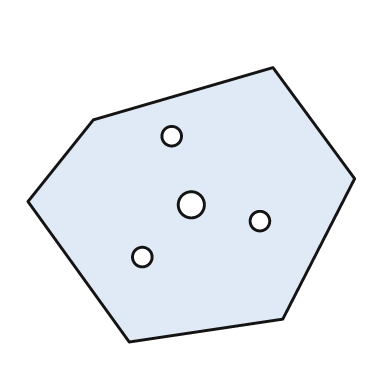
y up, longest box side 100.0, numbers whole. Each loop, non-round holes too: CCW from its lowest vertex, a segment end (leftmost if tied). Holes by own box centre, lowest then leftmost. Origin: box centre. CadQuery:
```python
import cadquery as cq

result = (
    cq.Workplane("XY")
    .moveTo(-19.0, -42.0)
    .lineTo(28.0, -35.0)
    .lineTo(50.0, 8.0)
    .lineTo(25.0, 42.0)
    .lineTo(-30.0, 26.0)
    .lineTo(-50.0, 1.0)
    .close()
    .moveTo(-15.0, -16.0)
    .circle(3.0)
    .moveTo(21.0, -5.0)
    .circle(3.0)
    .moveTo(0.0, 0.0)
    .circle(4.0)
    .moveTo(-6.0, 21.0)
    .circle(3.0)
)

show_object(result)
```